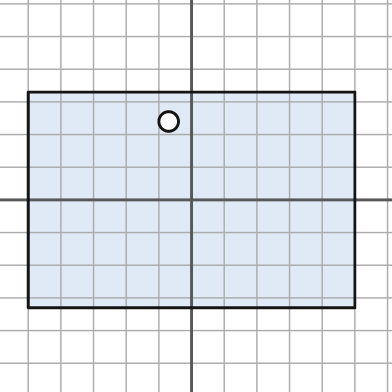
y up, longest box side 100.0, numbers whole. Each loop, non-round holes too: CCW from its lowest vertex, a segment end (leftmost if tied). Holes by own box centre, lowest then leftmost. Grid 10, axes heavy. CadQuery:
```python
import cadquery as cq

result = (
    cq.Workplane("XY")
    .moveTo(-50.0, -33.0)
    .lineTo(50.0, -33.0)
    .lineTo(50.0, 33.0)
    .lineTo(-50.0, 33.0)
    .close()
    .moveTo(-7.0, 24.0)
    .circle(3.0)
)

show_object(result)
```